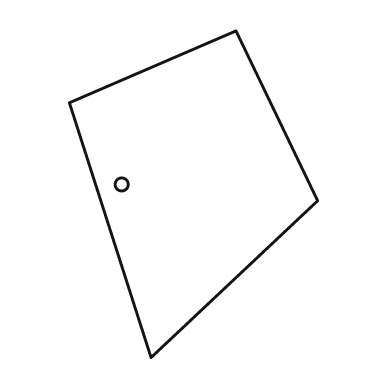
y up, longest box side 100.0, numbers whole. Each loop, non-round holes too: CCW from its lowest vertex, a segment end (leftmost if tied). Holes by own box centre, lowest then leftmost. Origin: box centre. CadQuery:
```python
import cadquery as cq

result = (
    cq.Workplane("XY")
    .moveTo(-13.0, -50.0)
    .lineTo(38.0, -2.0)
    .lineTo(13.0, 50.0)
    .lineTo(-38.0, 28.0)
    .close()
    .moveTo(-22.0, 3.0)
    .circle(2.0)
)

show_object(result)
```